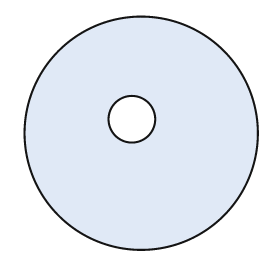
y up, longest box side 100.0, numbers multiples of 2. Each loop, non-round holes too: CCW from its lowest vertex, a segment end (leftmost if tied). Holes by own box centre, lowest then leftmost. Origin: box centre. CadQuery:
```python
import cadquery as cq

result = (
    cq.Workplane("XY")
    .moveTo(0.0, 0.0)
    .circle(50.0)
    .moveTo(-4.0, 6.0)
    .circle(10.0)
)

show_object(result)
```